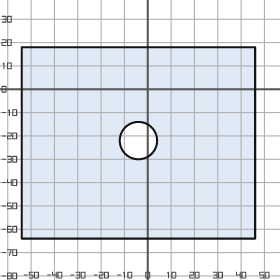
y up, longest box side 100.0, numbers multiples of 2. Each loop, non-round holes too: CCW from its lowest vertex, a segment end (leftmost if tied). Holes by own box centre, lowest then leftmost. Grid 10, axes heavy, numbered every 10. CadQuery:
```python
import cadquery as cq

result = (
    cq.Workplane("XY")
    .moveTo(-54.0, -64.0)
    .lineTo(46.0, -64.0)
    .lineTo(46.0, 18.0)
    .lineTo(-54.0, 18.0)
    .close()
    .moveTo(-4.0, -22.0)
    .circle(8.0)
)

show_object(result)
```